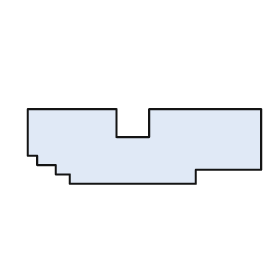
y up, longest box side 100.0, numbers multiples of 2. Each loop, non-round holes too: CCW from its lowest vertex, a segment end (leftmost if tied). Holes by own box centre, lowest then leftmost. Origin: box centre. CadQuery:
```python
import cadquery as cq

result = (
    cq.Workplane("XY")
    .moveTo(-32.0, -16.0)
    .lineTo(22.0, -16.0)
    .lineTo(22.0, -10.0)
    .lineTo(50.0, -10.0)
    .lineTo(50.0, 16.0)
    .lineTo(2.0, 16.0)
    .lineTo(2.0, 4.0)
    .lineTo(-12.0, 4.0)
    .lineTo(-12.0, 16.0)
    .lineTo(-50.0, 16.0)
    .lineTo(-50.0, -4.0)
    .lineTo(-46.0, -4.0)
    .lineTo(-46.0, -8.0)
    .lineTo(-38.0, -8.0)
    .lineTo(-38.0, -12.0)
    .lineTo(-32.0, -12.0)
    .close()
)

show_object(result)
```